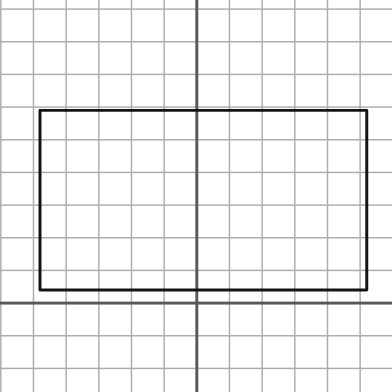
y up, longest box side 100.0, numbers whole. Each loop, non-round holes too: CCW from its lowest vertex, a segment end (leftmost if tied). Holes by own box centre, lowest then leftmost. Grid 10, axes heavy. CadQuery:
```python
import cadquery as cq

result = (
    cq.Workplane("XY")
    .moveTo(-48.0, 4.0)
    .lineTo(52.0, 4.0)
    .lineTo(52.0, 59.0)
    .lineTo(-48.0, 59.0)
    .close()
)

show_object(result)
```